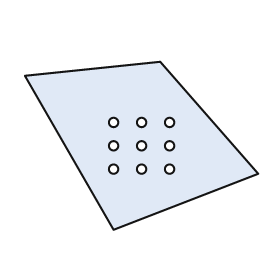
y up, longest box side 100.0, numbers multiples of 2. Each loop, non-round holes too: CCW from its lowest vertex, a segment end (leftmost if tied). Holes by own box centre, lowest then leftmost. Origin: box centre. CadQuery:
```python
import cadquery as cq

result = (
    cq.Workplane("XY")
    .moveTo(-12.0, -36.0)
    .lineTo(50.0, -12.0)
    .lineTo(8.0, 36.0)
    .lineTo(-50.0, 30.0)
    .close()
    .moveTo(-12.0, -10.0)
    .circle(2.0)
    .moveTo(0.0, -10.0)
    .circle(2.0)
    .moveTo(12.0, -10.0)
    .circle(2.0)
    .moveTo(-12.0, 0.0)
    .circle(2.0)
    .moveTo(0.0, 0.0)
    .circle(2.0)
    .moveTo(12.0, 0.0)
    .circle(2.0)
    .moveTo(-12.0, 10.0)
    .circle(2.0)
    .moveTo(0.0, 10.0)
    .circle(2.0)
    .moveTo(12.0, 10.0)
    .circle(2.0)
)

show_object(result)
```